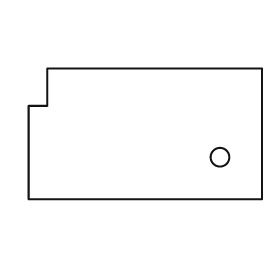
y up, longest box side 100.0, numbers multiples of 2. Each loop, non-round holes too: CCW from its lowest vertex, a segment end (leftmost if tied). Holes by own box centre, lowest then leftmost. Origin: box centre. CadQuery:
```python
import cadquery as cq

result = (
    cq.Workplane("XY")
    .moveTo(-50.0, -28.0)
    .lineTo(50.0, -28.0)
    .lineTo(50.0, 28.0)
    .lineTo(-42.0, 28.0)
    .lineTo(-42.0, 12.0)
    .lineTo(-50.0, 12.0)
    .close()
    .moveTo(32.0, -10.0)
    .circle(4.0)
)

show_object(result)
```